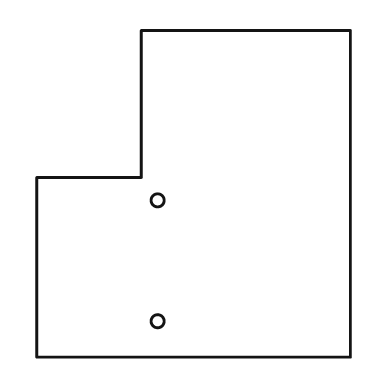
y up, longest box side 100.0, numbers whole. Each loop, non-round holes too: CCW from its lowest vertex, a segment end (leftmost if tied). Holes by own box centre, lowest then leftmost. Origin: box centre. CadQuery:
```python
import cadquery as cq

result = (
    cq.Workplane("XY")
    .moveTo(-48.0, -50.0)
    .lineTo(48.0, -50.0)
    .lineTo(48.0, 50.0)
    .lineTo(-16.0, 50.0)
    .lineTo(-16.0, 5.0)
    .lineTo(-48.0, 5.0)
    .close()
    .moveTo(-11.0, -39.0)
    .circle(2.0)
    .moveTo(-11.0, -2.0)
    .circle(2.0)
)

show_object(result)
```